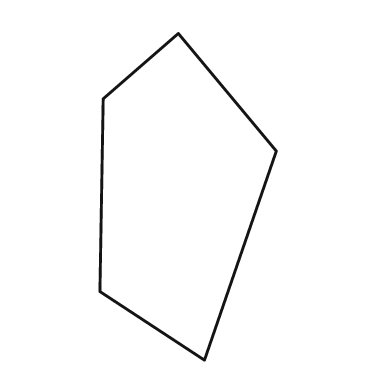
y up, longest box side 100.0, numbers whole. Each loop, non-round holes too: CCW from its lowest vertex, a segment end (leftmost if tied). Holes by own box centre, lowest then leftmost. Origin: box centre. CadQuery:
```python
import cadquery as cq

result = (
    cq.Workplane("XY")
    .moveTo(5.0, -50.0)
    .lineTo(27.0, 14.0)
    .lineTo(-3.0, 50.0)
    .lineTo(-26.0, 30.0)
    .lineTo(-27.0, -29.0)
    .close()
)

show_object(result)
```